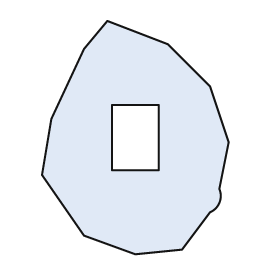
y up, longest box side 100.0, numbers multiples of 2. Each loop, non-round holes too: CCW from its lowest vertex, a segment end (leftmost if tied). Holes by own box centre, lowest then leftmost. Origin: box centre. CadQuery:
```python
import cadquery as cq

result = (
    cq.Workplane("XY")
    .moveTo(0.0, -50.0)
    .lineTo(20.0, -48.0)
    .lineTo(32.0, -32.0)
    .threePointArc((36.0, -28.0), (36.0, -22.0))
    .lineTo(40.0, -2.0)
    .lineTo(32.0, 22.0)
    .lineTo(14.0, 40.0)
    .lineTo(-12.0, 50.0)
    .lineTo(-22.0, 38.0)
    .lineTo(-36.0, 8.0)
    .lineTo(-40.0, -16.0)
    .lineTo(-22.0, -42.0)
    .close()
    .moveTo(-10.0, -14.0)
    .lineTo(10.0, -14.0)
    .lineTo(10.0, 14.0)
    .lineTo(-10.0, 14.0)
    .close()
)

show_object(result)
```